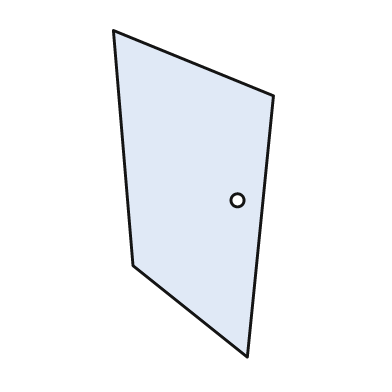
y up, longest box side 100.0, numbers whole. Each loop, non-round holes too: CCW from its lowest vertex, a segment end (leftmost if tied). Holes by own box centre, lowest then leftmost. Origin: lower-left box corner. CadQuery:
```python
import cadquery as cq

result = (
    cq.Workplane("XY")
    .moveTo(41.0, 0.0)
    .lineTo(49.0, 80.0)
    .lineTo(0.0, 100.0)
    .lineTo(6.0, 28.0)
    .close()
    .moveTo(38.0, 48.0)
    .circle(2.0)
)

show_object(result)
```